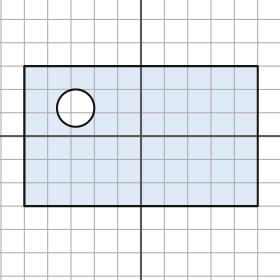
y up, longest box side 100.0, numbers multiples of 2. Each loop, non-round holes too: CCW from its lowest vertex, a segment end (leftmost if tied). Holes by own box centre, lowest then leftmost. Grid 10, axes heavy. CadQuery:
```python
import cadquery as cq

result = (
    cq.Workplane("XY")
    .moveTo(-50.0, -30.0)
    .lineTo(50.0, -30.0)
    .lineTo(50.0, 30.0)
    .lineTo(-50.0, 30.0)
    .close()
    .moveTo(-28.0, 12.0)
    .circle(8.0)
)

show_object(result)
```